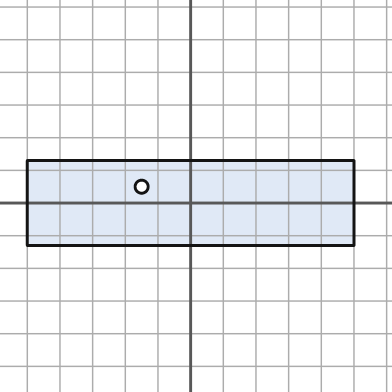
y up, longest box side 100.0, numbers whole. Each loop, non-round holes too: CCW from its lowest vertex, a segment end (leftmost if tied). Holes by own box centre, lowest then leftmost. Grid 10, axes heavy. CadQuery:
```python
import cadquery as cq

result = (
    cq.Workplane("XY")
    .moveTo(-50.0, -13.0)
    .lineTo(50.0, -13.0)
    .lineTo(50.0, 13.0)
    .lineTo(-50.0, 13.0)
    .close()
    .moveTo(-15.0, 5.0)
    .circle(2.0)
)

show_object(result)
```